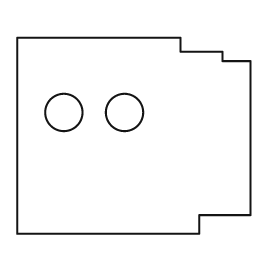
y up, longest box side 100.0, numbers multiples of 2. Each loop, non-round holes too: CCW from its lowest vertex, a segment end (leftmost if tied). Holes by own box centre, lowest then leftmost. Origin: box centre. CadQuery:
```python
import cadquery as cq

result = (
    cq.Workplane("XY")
    .moveTo(-50.0, -42.0)
    .lineTo(28.0, -42.0)
    .lineTo(28.0, -34.0)
    .lineTo(50.0, -34.0)
    .lineTo(50.0, 32.0)
    .lineTo(38.0, 32.0)
    .lineTo(38.0, 36.0)
    .lineTo(20.0, 36.0)
    .lineTo(20.0, 42.0)
    .lineTo(-50.0, 42.0)
    .close()
    .moveTo(-30.0, 10.0)
    .circle(8.0)
    .moveTo(-4.0, 10.0)
    .circle(8.0)
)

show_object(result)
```